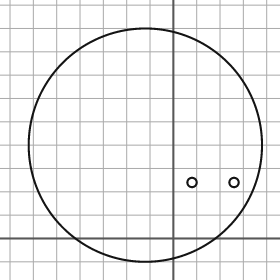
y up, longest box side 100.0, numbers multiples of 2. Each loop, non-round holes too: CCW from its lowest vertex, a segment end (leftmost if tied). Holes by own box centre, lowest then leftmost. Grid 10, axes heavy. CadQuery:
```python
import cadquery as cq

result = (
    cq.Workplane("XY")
    .moveTo(-12.0, 40.0)
    .circle(50.0)
    .moveTo(8.0, 24.0)
    .circle(2.0)
    .moveTo(26.0, 24.0)
    .circle(2.0)
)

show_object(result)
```